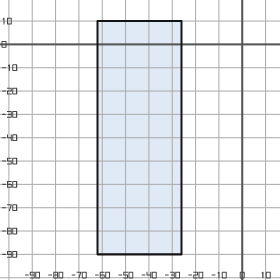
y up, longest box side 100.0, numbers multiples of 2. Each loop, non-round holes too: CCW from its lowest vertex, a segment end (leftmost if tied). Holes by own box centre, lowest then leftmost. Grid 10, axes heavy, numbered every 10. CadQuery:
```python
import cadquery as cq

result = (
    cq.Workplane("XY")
    .moveTo(-62.0, -90.0)
    .lineTo(-26.0, -90.0)
    .lineTo(-26.0, 10.0)
    .lineTo(-62.0, 10.0)
    .close()
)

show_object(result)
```